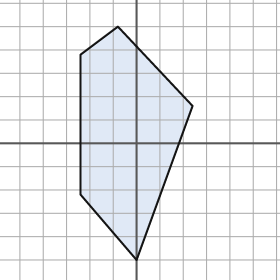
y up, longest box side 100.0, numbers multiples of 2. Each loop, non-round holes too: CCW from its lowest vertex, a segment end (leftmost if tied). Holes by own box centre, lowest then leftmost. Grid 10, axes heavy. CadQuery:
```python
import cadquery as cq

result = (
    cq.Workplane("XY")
    .moveTo(0.0, -50.0)
    .lineTo(24.0, 16.0)
    .lineTo(-8.0, 50.0)
    .lineTo(-24.0, 38.0)
    .lineTo(-24.0, -22.0)
    .close()
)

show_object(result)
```